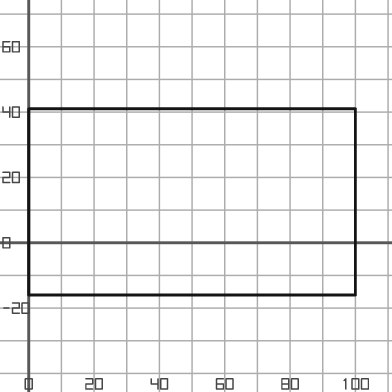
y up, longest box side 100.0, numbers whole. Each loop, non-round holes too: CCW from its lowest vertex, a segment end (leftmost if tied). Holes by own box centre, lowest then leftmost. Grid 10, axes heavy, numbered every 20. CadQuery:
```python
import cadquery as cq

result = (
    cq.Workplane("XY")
    .moveTo(0.0, -16.0)
    .lineTo(100.0, -16.0)
    .lineTo(100.0, 41.0)
    .lineTo(0.0, 41.0)
    .close()
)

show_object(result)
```